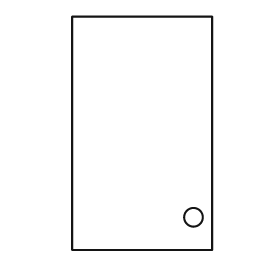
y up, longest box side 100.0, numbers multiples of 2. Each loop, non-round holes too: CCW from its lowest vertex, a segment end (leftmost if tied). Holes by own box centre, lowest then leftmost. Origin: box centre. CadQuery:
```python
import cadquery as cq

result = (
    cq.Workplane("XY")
    .moveTo(-30.0, -50.0)
    .lineTo(30.0, -50.0)
    .lineTo(30.0, 50.0)
    .lineTo(-30.0, 50.0)
    .close()
    .moveTo(22.0, -36.0)
    .circle(4.0)
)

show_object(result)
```